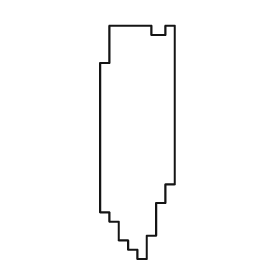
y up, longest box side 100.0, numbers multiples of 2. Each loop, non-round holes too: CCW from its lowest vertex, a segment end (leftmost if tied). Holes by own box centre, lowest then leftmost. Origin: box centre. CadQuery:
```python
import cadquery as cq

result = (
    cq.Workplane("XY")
    .moveTo(0.0, -50.0)
    .lineTo(4.0, -50.0)
    .lineTo(4.0, -40.0)
    .lineTo(8.0, -40.0)
    .lineTo(8.0, -26.0)
    .lineTo(12.0, -26.0)
    .lineTo(12.0, -18.0)
    .lineTo(16.0, -18.0)
    .lineTo(16.0, 50.0)
    .lineTo(12.0, 50.0)
    .lineTo(12.0, 46.0)
    .lineTo(6.0, 46.0)
    .lineTo(6.0, 50.0)
    .lineTo(-12.0, 50.0)
    .lineTo(-12.0, 34.0)
    .lineTo(-16.0, 34.0)
    .lineTo(-16.0, -30.0)
    .lineTo(-12.0, -30.0)
    .lineTo(-12.0, -34.0)
    .lineTo(-8.0, -34.0)
    .lineTo(-8.0, -42.0)
    .lineTo(-4.0, -42.0)
    .lineTo(-4.0, -46.0)
    .lineTo(0.0, -46.0)
    .close()
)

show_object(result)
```